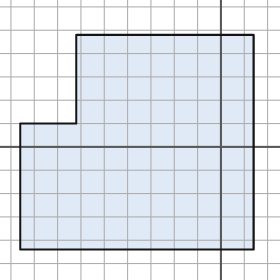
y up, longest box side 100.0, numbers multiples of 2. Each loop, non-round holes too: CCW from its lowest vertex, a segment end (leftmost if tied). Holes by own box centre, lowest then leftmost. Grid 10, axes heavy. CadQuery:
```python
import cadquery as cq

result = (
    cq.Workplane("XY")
    .moveTo(-86.0, -44.0)
    .lineTo(14.0, -44.0)
    .lineTo(14.0, 48.0)
    .lineTo(-62.0, 48.0)
    .lineTo(-62.0, 10.0)
    .lineTo(-86.0, 10.0)
    .close()
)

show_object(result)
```